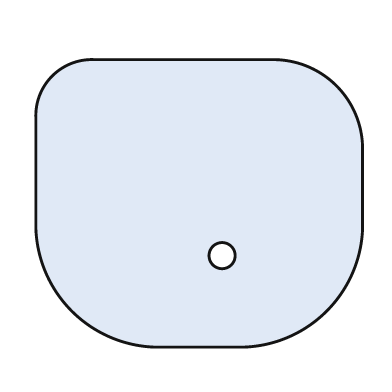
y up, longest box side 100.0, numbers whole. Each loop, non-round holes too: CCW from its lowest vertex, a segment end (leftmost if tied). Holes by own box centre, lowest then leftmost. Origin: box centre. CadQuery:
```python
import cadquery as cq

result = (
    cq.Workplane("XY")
    .moveTo(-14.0, -44.0)
    .lineTo(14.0, -44.0)
    .threePointArc((39.0, -33.0), (50.0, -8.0))
    .lineTo(50.0, 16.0)
    .threePointArc((42.0, 36.0), (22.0, 44.0))
    .lineTo(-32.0, 44.0)
    .threePointArc((-45.0, 39.0), (-50.0, 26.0))
    .lineTo(-50.0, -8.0)
    .threePointArc((-39.0, -33.0), (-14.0, -44.0))
    .close()
    .moveTo(7.0, -16.0)
    .circle(4.0)
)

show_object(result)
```